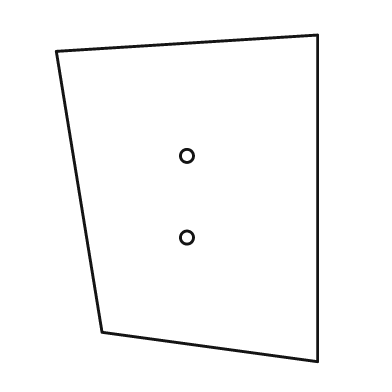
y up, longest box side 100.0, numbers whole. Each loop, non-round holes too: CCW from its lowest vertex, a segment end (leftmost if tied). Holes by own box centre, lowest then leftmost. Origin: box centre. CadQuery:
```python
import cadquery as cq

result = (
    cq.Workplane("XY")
    .moveTo(40.0, -50.0)
    .lineTo(40.0, 50.0)
    .lineTo(-40.0, 45.0)
    .lineTo(-26.0, -41.0)
    .close()
    .moveTo(0.0, -12.0)
    .circle(2.0)
    .moveTo(0.0, 13.0)
    .circle(2.0)
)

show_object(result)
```